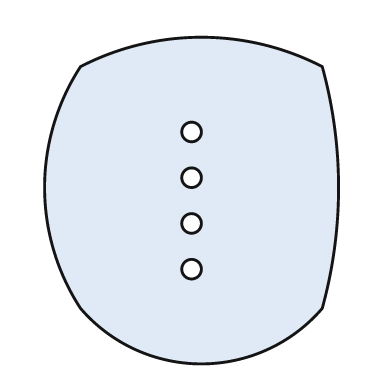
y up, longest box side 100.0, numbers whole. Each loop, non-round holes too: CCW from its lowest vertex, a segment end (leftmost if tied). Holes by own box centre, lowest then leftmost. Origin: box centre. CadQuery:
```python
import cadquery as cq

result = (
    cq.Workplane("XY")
    .moveTo(-34.0, -33.0)
    .threePointArc((3.0, -50.0), (40.0, -33.0))
    .threePointArc((45.0, 4.0), (40.0, 41.0))
    .threePointArc((3.0, 50.0), (-34.0, 41.0))
    .threePointArc((-45.0, 4.0), (-34.0, -33.0))
    .close()
    .moveTo(0.0, -21.0)
    .circle(3.0)
    .moveTo(0.0, -7.0)
    .circle(3.0)
    .moveTo(0.0, 7.0)
    .circle(3.0)
    .moveTo(0.0, 21.0)
    .circle(3.0)
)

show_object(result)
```